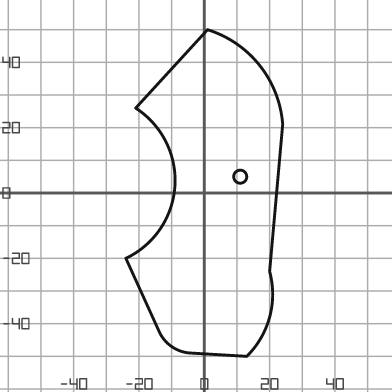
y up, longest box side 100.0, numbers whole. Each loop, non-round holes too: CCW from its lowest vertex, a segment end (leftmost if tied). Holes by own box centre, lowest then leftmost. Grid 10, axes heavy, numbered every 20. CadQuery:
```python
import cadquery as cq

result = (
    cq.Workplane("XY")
    .moveTo(13.0, -50.0)
    .threePointArc((20.0, -38.0), (20.0, -24.0))
    .lineTo(24.0, 21.0)
    .threePointArc((17.0, 39.0), (1.0, 50.0))
    .lineTo(-21.0, 26.0)
    .threePointArc((-9.0, 2.0), (-24.0, -20.0))
    .lineTo(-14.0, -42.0)
    .threePointArc((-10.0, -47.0), (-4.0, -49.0))
    .close()
    .moveTo(11.0, 5.0)
    .circle(2.0)
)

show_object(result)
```